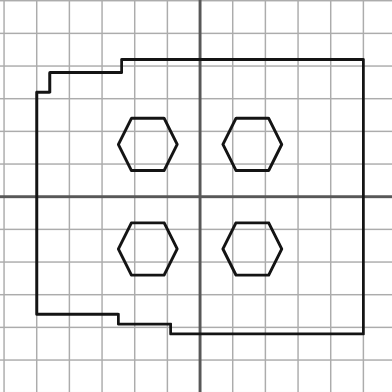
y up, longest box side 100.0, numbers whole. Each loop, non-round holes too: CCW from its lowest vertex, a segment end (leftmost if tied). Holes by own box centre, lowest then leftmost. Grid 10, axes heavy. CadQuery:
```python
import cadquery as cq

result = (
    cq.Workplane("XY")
    .moveTo(-9.0, -42.0)
    .lineTo(50.0, -42.0)
    .lineTo(50.0, 42.0)
    .lineTo(-24.0, 42.0)
    .lineTo(-24.0, 38.0)
    .lineTo(-46.0, 38.0)
    .lineTo(-46.0, 32.0)
    .lineTo(-50.0, 32.0)
    .lineTo(-50.0, -36.0)
    .lineTo(-25.0, -36.0)
    .lineTo(-25.0, -39.0)
    .lineTo(-9.0, -39.0)
    .close()
    .moveTo(-21.0, -24.0)
    .lineTo(-11.0, -24.0)
    .lineTo(-7.0, -16.0)
    .lineTo(-11.0, -8.0)
    .lineTo(-21.0, -8.0)
    .lineTo(-25.0, -16.0)
    .close()
    .moveTo(11.0, -24.0)
    .lineTo(21.0, -24.0)
    .lineTo(25.0, -16.0)
    .lineTo(21.0, -8.0)
    .lineTo(11.0, -8.0)
    .lineTo(7.0, -16.0)
    .close()
    .moveTo(-21.0, 8.0)
    .lineTo(-11.0, 8.0)
    .lineTo(-7.0, 16.0)
    .lineTo(-11.0, 24.0)
    .lineTo(-21.0, 24.0)
    .lineTo(-25.0, 16.0)
    .close()
    .moveTo(11.0, 8.0)
    .lineTo(21.0, 8.0)
    .lineTo(25.0, 16.0)
    .lineTo(21.0, 24.0)
    .lineTo(11.0, 24.0)
    .lineTo(7.0, 16.0)
    .close()
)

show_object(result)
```